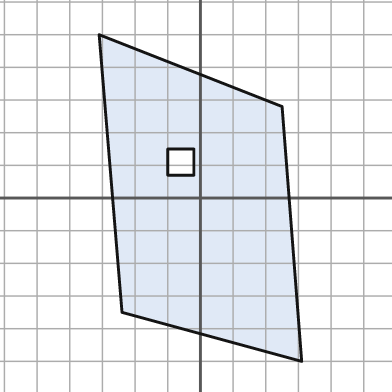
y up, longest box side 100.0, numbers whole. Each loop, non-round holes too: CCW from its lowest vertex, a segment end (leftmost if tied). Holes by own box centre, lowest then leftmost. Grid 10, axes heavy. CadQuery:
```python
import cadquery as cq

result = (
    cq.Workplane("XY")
    .moveTo(31.0, -50.0)
    .lineTo(25.0, 28.0)
    .lineTo(-31.0, 50.0)
    .lineTo(-24.0, -35.0)
    .close()
    .moveTo(-10.0, 7.0)
    .lineTo(-2.0, 7.0)
    .lineTo(-2.0, 15.0)
    .lineTo(-10.0, 15.0)
    .close()
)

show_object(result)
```